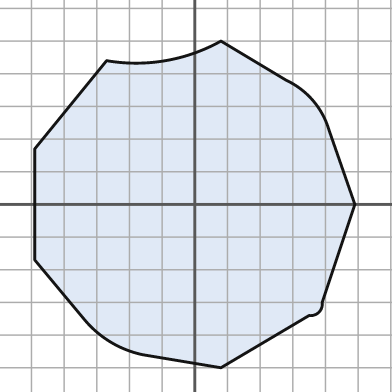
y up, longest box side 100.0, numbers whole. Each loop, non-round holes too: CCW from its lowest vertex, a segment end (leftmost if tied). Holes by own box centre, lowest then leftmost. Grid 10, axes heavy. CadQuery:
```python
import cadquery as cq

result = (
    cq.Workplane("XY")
    .moveTo(8.0, -50.0)
    .lineTo(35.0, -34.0)
    .threePointArc((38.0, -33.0), (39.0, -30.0))
    .lineTo(49.0, 0.0)
    .lineTo(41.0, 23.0)
    .threePointArc((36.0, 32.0), (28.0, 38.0))
    .lineTo(8.0, 50.0)
    .threePointArc((-9.0, 44.0), (-27.0, 44.0))
    .lineTo(-49.0, 17.0)
    .lineTo(-49.0, -17.0)
    .lineTo(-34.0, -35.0)
    .threePointArc((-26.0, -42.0), (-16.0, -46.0))
    .close()
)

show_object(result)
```